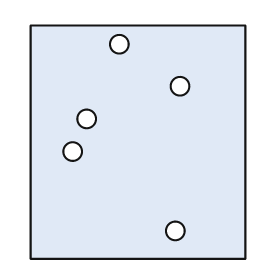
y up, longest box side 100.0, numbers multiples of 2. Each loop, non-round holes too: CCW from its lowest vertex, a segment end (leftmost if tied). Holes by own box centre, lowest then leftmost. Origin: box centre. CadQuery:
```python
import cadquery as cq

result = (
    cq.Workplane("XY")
    .moveTo(-46.0, -50.0)
    .lineTo(46.0, -50.0)
    .lineTo(46.0, 50.0)
    .lineTo(-46.0, 50.0)
    .close()
    .moveTo(16.0, -38.0)
    .circle(4.0)
    .moveTo(-28.0, -4.0)
    .circle(4.0)
    .moveTo(-22.0, 10.0)
    .circle(4.0)
    .moveTo(18.0, 24.0)
    .circle(4.0)
    .moveTo(-8.0, 42.0)
    .circle(4.0)
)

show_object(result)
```